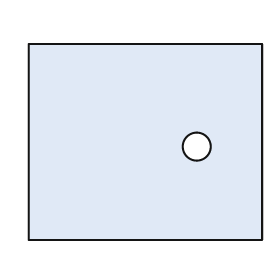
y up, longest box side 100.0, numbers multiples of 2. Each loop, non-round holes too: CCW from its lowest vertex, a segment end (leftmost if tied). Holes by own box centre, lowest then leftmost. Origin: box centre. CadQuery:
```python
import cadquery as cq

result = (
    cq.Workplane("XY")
    .moveTo(-50.0, -42.0)
    .lineTo(50.0, -42.0)
    .lineTo(50.0, 42.0)
    .lineTo(-50.0, 42.0)
    .close()
    .moveTo(22.0, -2.0)
    .circle(6.0)
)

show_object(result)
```